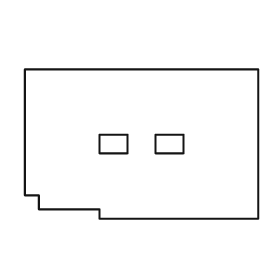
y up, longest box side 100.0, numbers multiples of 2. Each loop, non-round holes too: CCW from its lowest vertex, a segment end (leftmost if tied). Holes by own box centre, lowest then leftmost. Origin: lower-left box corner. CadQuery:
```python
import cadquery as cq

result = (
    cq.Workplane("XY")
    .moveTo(32.0, 0.0)
    .lineTo(100.0, 0.0)
    .lineTo(100.0, 64.0)
    .lineTo(0.0, 64.0)
    .lineTo(0.0, 10.0)
    .lineTo(6.0, 10.0)
    .lineTo(6.0, 4.0)
    .lineTo(32.0, 4.0)
    .close()
    .moveTo(32.0, 28.0)
    .lineTo(44.0, 28.0)
    .lineTo(44.0, 36.0)
    .lineTo(32.0, 36.0)
    .close()
    .moveTo(56.0, 28.0)
    .lineTo(68.0, 28.0)
    .lineTo(68.0, 36.0)
    .lineTo(56.0, 36.0)
    .close()
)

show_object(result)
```